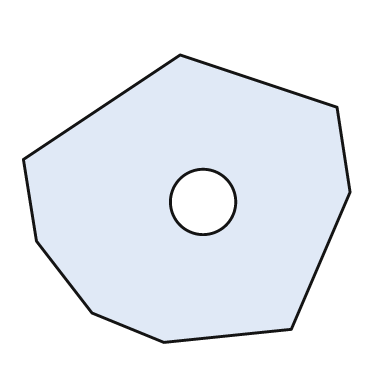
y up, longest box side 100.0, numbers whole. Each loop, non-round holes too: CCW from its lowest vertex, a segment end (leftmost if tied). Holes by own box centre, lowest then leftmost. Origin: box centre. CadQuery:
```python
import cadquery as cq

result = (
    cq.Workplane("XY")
    .moveTo(-7.0, -44.0)
    .lineTo(32.0, -40.0)
    .lineTo(50.0, 2.0)
    .lineTo(46.0, 28.0)
    .lineTo(-2.0, 44.0)
    .lineTo(-50.0, 12.0)
    .lineTo(-46.0, -13.0)
    .lineTo(-29.0, -35.0)
    .close()
    .moveTo(5.0, -1.0)
    .circle(10.0)
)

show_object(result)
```